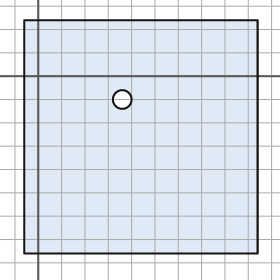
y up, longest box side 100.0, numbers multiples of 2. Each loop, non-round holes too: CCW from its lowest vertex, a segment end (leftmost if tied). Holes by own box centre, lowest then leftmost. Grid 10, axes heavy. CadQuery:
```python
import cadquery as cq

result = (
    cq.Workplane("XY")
    .moveTo(-6.0, -76.0)
    .lineTo(94.0, -76.0)
    .lineTo(94.0, 24.0)
    .lineTo(-6.0, 24.0)
    .close()
    .moveTo(36.0, -10.0)
    .circle(4.0)
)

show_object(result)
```